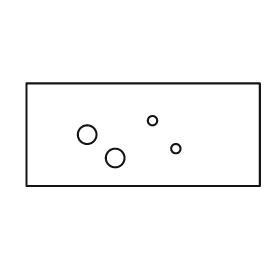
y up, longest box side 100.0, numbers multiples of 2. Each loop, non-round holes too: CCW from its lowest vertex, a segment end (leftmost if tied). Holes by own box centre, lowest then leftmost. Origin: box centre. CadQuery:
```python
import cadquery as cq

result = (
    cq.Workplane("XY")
    .moveTo(-50.0, -22.0)
    .lineTo(50.0, -22.0)
    .lineTo(50.0, 22.0)
    .lineTo(-50.0, 22.0)
    .close()
    .moveTo(-12.0, -10.0)
    .circle(4.0)
    .moveTo(14.0, -6.0)
    .circle(2.0)
    .moveTo(-24.0, 0.0)
    .circle(4.0)
    .moveTo(4.0, 6.0)
    .circle(2.0)
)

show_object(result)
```